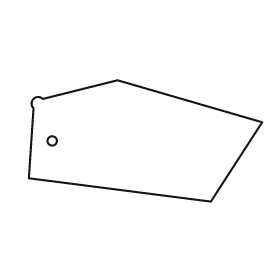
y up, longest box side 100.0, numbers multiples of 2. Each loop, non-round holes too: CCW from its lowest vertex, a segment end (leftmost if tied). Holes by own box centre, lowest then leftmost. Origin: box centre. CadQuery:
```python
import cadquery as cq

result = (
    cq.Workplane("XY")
    .moveTo(28.0, -26.0)
    .lineTo(50.0, 8.0)
    .lineTo(-12.0, 26.0)
    .lineTo(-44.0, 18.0)
    .threePointArc((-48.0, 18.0), (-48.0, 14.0))
    .lineTo(-50.0, -16.0)
    .close()
    .moveTo(-40.0, 0.0)
    .circle(2.0)
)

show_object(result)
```